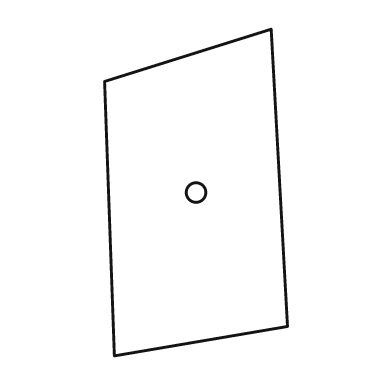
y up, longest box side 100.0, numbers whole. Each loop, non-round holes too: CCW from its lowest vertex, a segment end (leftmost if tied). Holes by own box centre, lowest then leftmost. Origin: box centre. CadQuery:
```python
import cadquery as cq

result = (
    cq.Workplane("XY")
    .moveTo(-25.0, -50.0)
    .lineTo(28.0, -41.0)
    .lineTo(23.0, 50.0)
    .lineTo(-28.0, 34.0)
    .close()
    .moveTo(0.0, 0.0)
    .circle(3.0)
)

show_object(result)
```